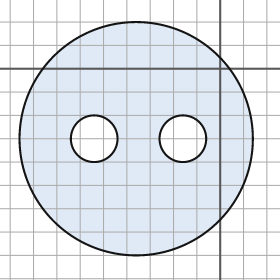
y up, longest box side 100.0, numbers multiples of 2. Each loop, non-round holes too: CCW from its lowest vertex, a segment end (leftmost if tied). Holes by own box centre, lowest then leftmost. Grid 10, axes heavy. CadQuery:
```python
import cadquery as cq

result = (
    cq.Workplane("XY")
    .moveTo(-36.0, -30.0)
    .circle(50.0)
    .moveTo(-54.0, -30.0)
    .circle(10.0)
    .moveTo(-16.0, -30.0)
    .circle(10.0)
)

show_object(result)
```